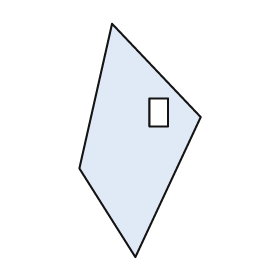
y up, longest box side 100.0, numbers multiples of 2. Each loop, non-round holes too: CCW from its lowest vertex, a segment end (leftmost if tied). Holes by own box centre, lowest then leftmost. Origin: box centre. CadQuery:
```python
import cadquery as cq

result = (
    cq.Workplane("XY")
    .moveTo(-2.0, -50.0)
    .lineTo(26.0, 10.0)
    .lineTo(-12.0, 50.0)
    .lineTo(-26.0, -12.0)
    .close()
    .moveTo(4.0, 6.0)
    .lineTo(12.0, 6.0)
    .lineTo(12.0, 18.0)
    .lineTo(4.0, 18.0)
    .close()
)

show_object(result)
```